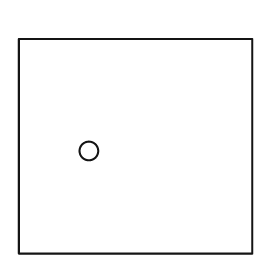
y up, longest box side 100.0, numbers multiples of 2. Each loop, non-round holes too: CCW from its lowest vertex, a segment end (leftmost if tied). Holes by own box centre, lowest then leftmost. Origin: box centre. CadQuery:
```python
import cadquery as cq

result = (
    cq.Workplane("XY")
    .moveTo(-50.0, -46.0)
    .lineTo(50.0, -46.0)
    .lineTo(50.0, 46.0)
    .lineTo(-50.0, 46.0)
    .close()
    .moveTo(-20.0, -2.0)
    .circle(4.0)
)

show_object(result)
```